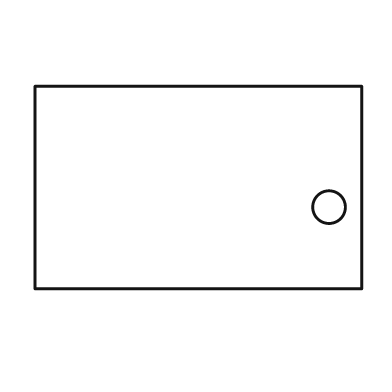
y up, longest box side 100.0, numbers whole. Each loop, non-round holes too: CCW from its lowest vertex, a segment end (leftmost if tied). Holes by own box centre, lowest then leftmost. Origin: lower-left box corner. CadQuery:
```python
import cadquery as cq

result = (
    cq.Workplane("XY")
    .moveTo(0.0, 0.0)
    .lineTo(100.0, 0.0)
    .lineTo(100.0, 62.0)
    .lineTo(0.0, 62.0)
    .close()
    .moveTo(90.0, 25.0)
    .circle(5.0)
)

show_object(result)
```